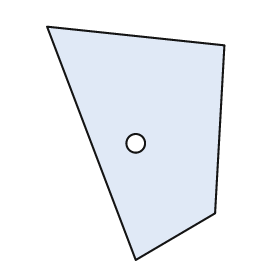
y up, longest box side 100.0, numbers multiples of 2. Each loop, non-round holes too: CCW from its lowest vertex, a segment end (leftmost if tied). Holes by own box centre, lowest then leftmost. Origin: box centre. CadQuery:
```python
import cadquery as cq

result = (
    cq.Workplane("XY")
    .moveTo(0.0, -50.0)
    .lineTo(34.0, -30.0)
    .lineTo(38.0, 42.0)
    .lineTo(-38.0, 50.0)
    .close()
    .moveTo(0.0, 0.0)
    .circle(4.0)
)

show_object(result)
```